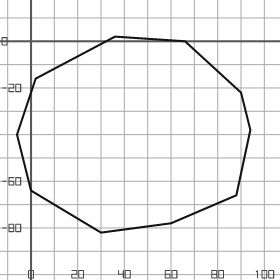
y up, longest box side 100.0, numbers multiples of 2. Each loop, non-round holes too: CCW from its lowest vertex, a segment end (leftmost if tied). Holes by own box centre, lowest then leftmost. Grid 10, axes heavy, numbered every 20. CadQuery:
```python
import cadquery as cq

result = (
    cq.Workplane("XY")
    .moveTo(30.0, -82.0)
    .lineTo(60.0, -78.0)
    .lineTo(88.0, -66.0)
    .lineTo(94.0, -38.0)
    .lineTo(90.0, -22.0)
    .lineTo(66.0, 0.0)
    .lineTo(36.0, 2.0)
    .lineTo(2.0, -16.0)
    .lineTo(-6.0, -40.0)
    .lineTo(0.0, -64.0)
    .close()
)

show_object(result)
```